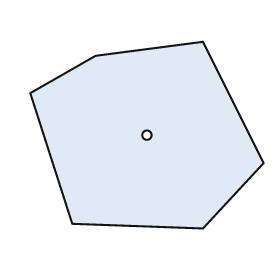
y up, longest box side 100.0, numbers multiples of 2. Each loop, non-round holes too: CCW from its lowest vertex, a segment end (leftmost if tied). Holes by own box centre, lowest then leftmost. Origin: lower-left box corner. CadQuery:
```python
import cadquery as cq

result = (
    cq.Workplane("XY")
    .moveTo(74.0, 0.0)
    .lineTo(100.0, 28.0)
    .lineTo(74.0, 80.0)
    .lineTo(28.0, 74.0)
    .lineTo(0.0, 58.0)
    .lineTo(18.0, 2.0)
    .close()
    .moveTo(50.0, 40.0)
    .circle(2.0)
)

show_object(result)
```